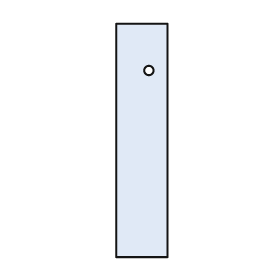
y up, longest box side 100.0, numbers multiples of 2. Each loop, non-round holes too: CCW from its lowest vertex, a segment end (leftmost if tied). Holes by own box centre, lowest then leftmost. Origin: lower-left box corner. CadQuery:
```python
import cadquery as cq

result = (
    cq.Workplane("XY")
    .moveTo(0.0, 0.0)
    .lineTo(22.0, 0.0)
    .lineTo(22.0, 100.0)
    .lineTo(0.0, 100.0)
    .close()
    .moveTo(14.0, 80.0)
    .circle(2.0)
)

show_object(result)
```